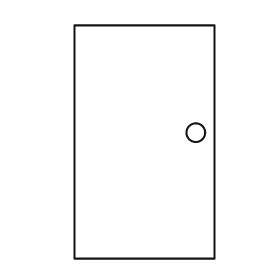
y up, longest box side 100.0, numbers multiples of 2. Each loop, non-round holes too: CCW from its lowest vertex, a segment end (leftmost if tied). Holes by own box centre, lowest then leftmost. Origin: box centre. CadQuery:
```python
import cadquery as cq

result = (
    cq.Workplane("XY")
    .moveTo(-30.0, -50.0)
    .lineTo(30.0, -50.0)
    .lineTo(30.0, 50.0)
    .lineTo(-30.0, 50.0)
    .close()
    .moveTo(22.0, 4.0)
    .circle(4.0)
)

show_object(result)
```